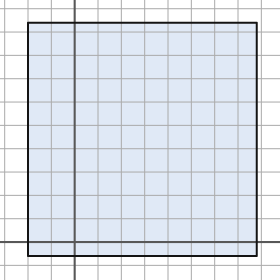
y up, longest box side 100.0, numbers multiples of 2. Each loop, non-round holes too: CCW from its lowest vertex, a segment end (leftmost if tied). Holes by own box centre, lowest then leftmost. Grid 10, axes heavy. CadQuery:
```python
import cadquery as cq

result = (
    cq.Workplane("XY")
    .moveTo(-20.0, -6.0)
    .lineTo(78.0, -6.0)
    .lineTo(78.0, 94.0)
    .lineTo(-20.0, 94.0)
    .close()
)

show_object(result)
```